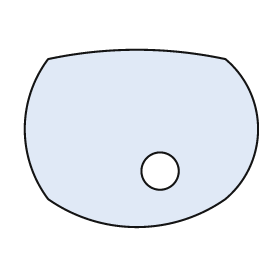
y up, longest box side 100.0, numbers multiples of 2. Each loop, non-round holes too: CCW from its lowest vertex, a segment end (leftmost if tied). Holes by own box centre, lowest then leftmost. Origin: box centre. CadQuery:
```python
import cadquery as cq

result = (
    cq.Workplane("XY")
    .moveTo(-40.0, -26.0)
    .threePointArc((-2.0, -38.0), (36.0, -26.0))
    .threePointArc((50.0, 4.0), (36.0, 34.0))
    .threePointArc((-2.0, 38.0), (-40.0, 34.0))
    .threePointArc((-50.0, 4.0), (-40.0, -26.0))
    .close()
    .moveTo(8.0, -14.0)
    .circle(8.0)
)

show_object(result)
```